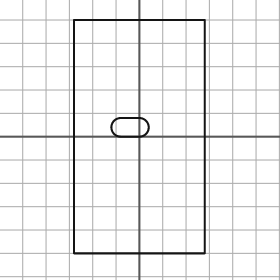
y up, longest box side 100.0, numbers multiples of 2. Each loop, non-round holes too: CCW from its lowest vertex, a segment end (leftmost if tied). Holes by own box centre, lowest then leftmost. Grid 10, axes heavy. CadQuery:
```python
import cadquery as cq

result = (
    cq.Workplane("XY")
    .moveTo(-28.0, -50.0)
    .lineTo(28.0, -50.0)
    .lineTo(28.0, 50.0)
    .lineTo(-28.0, 50.0)
    .close()
    .moveTo(-8.0, 0.0)
    .lineTo(0.0, 0.0)
    .threePointArc((4.0, 4.0), (0.0, 8.0))
    .lineTo(-8.0, 8.0)
    .threePointArc((-12.0, 4.0), (-8.0, 0.0))
    .close()
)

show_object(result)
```